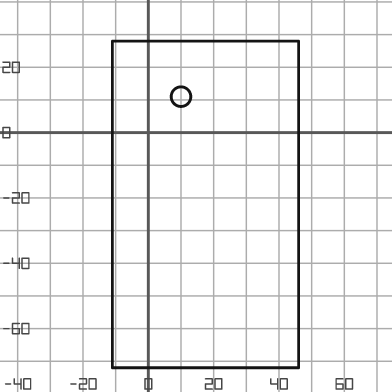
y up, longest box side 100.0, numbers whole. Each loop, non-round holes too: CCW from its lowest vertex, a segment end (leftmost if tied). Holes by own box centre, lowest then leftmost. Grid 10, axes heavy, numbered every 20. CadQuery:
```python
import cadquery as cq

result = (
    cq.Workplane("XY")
    .moveTo(-11.0, -72.0)
    .lineTo(46.0, -72.0)
    .lineTo(46.0, 28.0)
    .lineTo(-11.0, 28.0)
    .close()
    .moveTo(10.0, 11.0)
    .circle(3.0)
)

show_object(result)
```